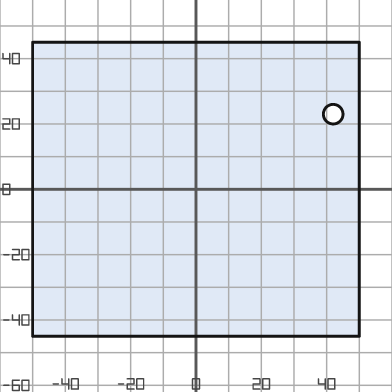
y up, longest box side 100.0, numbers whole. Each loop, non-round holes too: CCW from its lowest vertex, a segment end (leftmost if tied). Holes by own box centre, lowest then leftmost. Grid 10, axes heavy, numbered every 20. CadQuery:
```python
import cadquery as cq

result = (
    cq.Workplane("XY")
    .moveTo(-50.0, -45.0)
    .lineTo(50.0, -45.0)
    .lineTo(50.0, 45.0)
    .lineTo(-50.0, 45.0)
    .close()
    .moveTo(42.0, 23.0)
    .circle(3.0)
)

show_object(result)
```